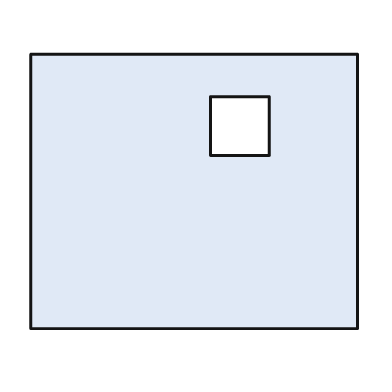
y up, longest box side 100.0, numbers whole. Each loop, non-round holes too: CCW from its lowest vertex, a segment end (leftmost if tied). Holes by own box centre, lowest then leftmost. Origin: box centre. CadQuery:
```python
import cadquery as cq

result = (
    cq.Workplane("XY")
    .moveTo(-50.0, -42.0)
    .lineTo(50.0, -42.0)
    .lineTo(50.0, 42.0)
    .lineTo(-50.0, 42.0)
    .close()
    .moveTo(5.0, 11.0)
    .lineTo(23.0, 11.0)
    .lineTo(23.0, 29.0)
    .lineTo(5.0, 29.0)
    .close()
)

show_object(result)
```